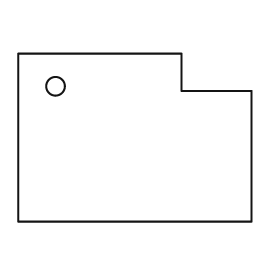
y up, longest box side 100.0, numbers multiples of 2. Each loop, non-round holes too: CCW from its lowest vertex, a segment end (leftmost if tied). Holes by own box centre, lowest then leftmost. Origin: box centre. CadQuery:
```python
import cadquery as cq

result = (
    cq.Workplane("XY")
    .moveTo(-50.0, -36.0)
    .lineTo(50.0, -36.0)
    .lineTo(50.0, 20.0)
    .lineTo(20.0, 20.0)
    .lineTo(20.0, 36.0)
    .lineTo(-50.0, 36.0)
    .close()
    .moveTo(-34.0, 22.0)
    .circle(4.0)
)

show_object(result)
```